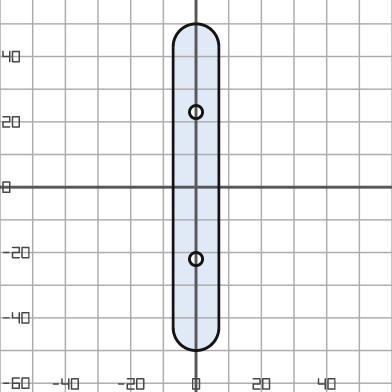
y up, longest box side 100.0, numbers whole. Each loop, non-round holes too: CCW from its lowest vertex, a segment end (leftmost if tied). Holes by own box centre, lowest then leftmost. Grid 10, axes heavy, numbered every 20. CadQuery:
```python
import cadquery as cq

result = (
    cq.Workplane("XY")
    .moveTo(-7.0, -43.0)
    .threePointArc((0.0, -50.0), (7.0, -43.0))
    .lineTo(7.0, 43.0)
    .threePointArc((0.0, 50.0), (-7.0, 43.0))
    .close()
    .moveTo(0.0, -22.0)
    .circle(2.0)
    .moveTo(0.0, 23.0)
    .circle(2.0)
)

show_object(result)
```